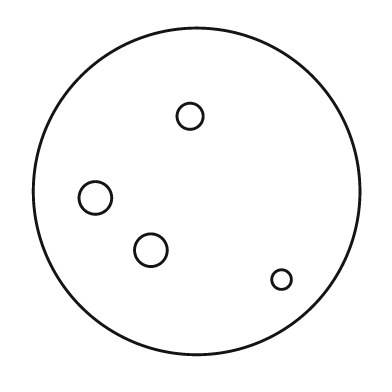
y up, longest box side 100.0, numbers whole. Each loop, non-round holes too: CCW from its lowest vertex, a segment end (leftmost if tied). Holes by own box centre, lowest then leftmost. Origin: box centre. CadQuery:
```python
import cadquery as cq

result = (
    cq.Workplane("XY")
    .moveTo(0.0, 0.0)
    .circle(50.0)
    .moveTo(26.0, -27.0)
    .circle(3.0)
    .moveTo(-14.0, -18.0)
    .circle(5.0)
    .moveTo(-31.0, -2.0)
    .circle(5.0)
    .moveTo(-2.0, 23.0)
    .circle(4.0)
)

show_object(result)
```